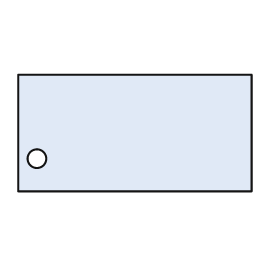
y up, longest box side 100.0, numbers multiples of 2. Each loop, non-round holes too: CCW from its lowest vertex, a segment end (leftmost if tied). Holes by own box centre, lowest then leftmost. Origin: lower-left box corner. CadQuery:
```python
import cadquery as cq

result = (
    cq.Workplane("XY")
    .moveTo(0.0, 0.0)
    .lineTo(100.0, 0.0)
    .lineTo(100.0, 50.0)
    .lineTo(0.0, 50.0)
    .close()
    .moveTo(8.0, 14.0)
    .circle(4.0)
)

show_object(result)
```